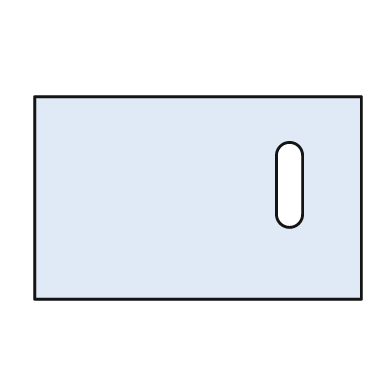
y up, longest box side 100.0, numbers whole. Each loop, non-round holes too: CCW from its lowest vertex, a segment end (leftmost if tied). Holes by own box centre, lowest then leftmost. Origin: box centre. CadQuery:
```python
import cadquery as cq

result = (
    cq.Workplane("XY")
    .moveTo(-50.0, -31.0)
    .lineTo(50.0, -31.0)
    .lineTo(50.0, 31.0)
    .lineTo(-50.0, 31.0)
    .close()
    .moveTo(24.0, -5.0)
    .threePointArc((28.0, -9.0), (32.0, -5.0))
    .lineTo(32.0, 13.0)
    .threePointArc((28.0, 17.0), (24.0, 13.0))
    .close()
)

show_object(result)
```